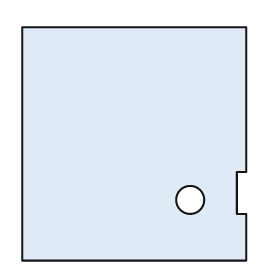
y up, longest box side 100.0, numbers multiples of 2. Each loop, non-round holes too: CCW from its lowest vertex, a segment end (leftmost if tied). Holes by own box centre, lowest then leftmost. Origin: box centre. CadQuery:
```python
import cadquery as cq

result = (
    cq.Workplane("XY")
    .moveTo(-48.0, -50.0)
    .lineTo(48.0, -50.0)
    .lineTo(48.0, -30.0)
    .lineTo(44.0, -30.0)
    .lineTo(44.0, -12.0)
    .lineTo(48.0, -12.0)
    .lineTo(48.0, 50.0)
    .lineTo(-48.0, 50.0)
    .close()
    .moveTo(24.0, -24.0)
    .circle(6.0)
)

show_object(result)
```